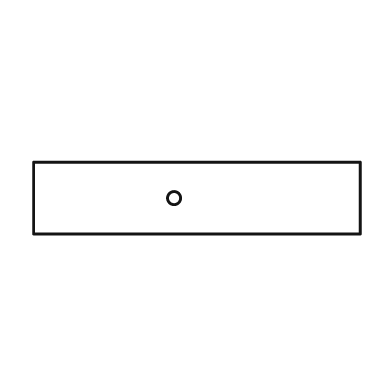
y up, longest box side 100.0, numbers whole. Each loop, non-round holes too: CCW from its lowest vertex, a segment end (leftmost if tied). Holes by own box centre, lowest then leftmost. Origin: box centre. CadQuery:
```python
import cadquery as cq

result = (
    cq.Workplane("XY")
    .moveTo(-50.0, -11.0)
    .lineTo(50.0, -11.0)
    .lineTo(50.0, 11.0)
    .lineTo(-50.0, 11.0)
    .close()
    .moveTo(-7.0, 0.0)
    .circle(2.0)
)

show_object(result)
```